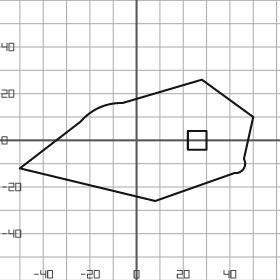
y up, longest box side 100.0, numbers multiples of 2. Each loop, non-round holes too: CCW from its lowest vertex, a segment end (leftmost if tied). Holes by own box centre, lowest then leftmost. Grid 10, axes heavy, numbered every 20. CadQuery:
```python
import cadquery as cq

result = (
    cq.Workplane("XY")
    .moveTo(8.0, -26.0)
    .lineTo(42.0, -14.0)
    .threePointArc((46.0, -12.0), (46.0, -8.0))
    .lineTo(50.0, 10.0)
    .lineTo(28.0, 26.0)
    .lineTo(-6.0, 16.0)
    .threePointArc((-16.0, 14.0), (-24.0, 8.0))
    .lineTo(-50.0, -12.0)
    .close()
    .moveTo(22.0, -4.0)
    .lineTo(30.0, -4.0)
    .lineTo(30.0, 4.0)
    .lineTo(22.0, 4.0)
    .close()
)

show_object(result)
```